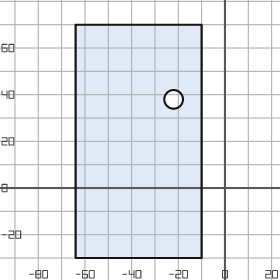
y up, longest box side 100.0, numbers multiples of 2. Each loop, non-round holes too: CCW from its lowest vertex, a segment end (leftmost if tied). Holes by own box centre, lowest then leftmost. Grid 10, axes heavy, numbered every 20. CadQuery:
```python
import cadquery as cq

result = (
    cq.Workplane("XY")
    .moveTo(-64.0, -30.0)
    .lineTo(-10.0, -30.0)
    .lineTo(-10.0, 70.0)
    .lineTo(-64.0, 70.0)
    .close()
    .moveTo(-22.0, 38.0)
    .circle(4.0)
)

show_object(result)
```